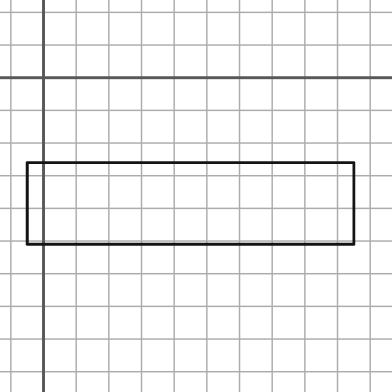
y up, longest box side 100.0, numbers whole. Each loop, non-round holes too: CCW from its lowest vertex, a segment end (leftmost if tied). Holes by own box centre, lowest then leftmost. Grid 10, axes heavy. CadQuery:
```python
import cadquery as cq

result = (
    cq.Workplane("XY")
    .moveTo(-5.0, -51.0)
    .lineTo(95.0, -51.0)
    .lineTo(95.0, -26.0)
    .lineTo(-5.0, -26.0)
    .close()
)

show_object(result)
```